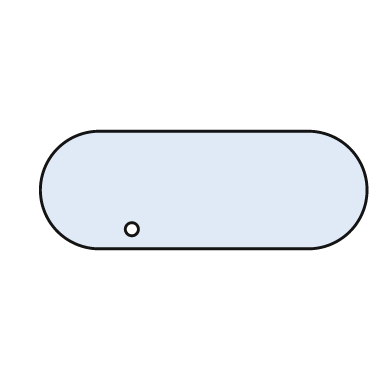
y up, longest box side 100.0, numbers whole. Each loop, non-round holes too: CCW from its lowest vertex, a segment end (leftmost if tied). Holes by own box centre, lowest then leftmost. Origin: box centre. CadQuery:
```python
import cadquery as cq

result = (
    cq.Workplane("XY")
    .moveTo(-32.0, -18.0)
    .lineTo(32.0, -18.0)
    .threePointArc((50.0, 0.0), (32.0, 18.0))
    .lineTo(-32.0, 18.0)
    .threePointArc((-50.0, 0.0), (-32.0, -18.0))
    .close()
    .moveTo(-22.0, -12.0)
    .circle(2.0)
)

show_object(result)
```